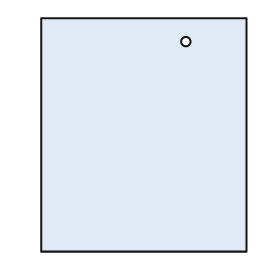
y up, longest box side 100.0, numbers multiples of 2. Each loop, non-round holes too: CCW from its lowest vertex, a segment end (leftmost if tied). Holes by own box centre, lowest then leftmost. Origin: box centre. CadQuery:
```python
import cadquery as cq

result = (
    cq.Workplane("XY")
    .moveTo(-44.0, -50.0)
    .lineTo(44.0, -50.0)
    .lineTo(44.0, 50.0)
    .lineTo(-44.0, 50.0)
    .close()
    .moveTo(18.0, 40.0)
    .circle(2.0)
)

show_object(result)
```